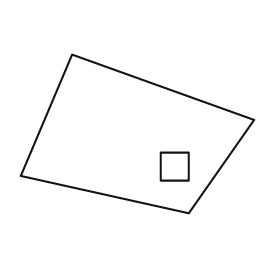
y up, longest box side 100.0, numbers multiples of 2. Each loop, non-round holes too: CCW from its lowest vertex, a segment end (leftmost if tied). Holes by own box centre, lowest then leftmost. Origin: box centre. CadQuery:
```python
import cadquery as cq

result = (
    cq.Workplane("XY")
    .moveTo(22.0, -34.0)
    .lineTo(50.0, 6.0)
    .lineTo(-28.0, 34.0)
    .lineTo(-50.0, -18.0)
    .close()
    .moveTo(10.0, -20.0)
    .lineTo(22.0, -20.0)
    .lineTo(22.0, -8.0)
    .lineTo(10.0, -8.0)
    .close()
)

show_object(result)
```